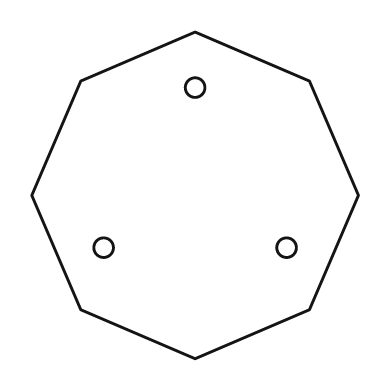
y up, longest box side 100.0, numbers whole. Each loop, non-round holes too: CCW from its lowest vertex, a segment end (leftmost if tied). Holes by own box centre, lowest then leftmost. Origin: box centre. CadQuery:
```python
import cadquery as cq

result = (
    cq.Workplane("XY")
    .moveTo(0.0, -50.0)
    .lineTo(35.0, -35.0)
    .lineTo(50.0, 0.0)
    .lineTo(35.0, 35.0)
    .lineTo(0.0, 50.0)
    .lineTo(-35.0, 35.0)
    .lineTo(-50.0, 0.0)
    .lineTo(-35.0, -35.0)
    .close()
    .moveTo(-28.0, -16.0)
    .circle(3.0)
    .moveTo(28.0, -16.0)
    .circle(3.0)
    .moveTo(0.0, 33.0)
    .circle(3.0)
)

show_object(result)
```